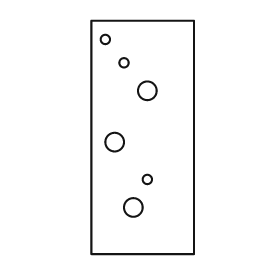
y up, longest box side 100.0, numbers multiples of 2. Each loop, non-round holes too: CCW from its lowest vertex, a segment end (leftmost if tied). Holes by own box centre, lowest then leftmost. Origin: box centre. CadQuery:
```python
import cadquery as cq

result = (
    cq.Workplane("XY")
    .moveTo(-22.0, -50.0)
    .lineTo(22.0, -50.0)
    .lineTo(22.0, 50.0)
    .lineTo(-22.0, 50.0)
    .close()
    .moveTo(-4.0, -30.0)
    .circle(4.0)
    .moveTo(2.0, -18.0)
    .circle(2.0)
    .moveTo(-12.0, -2.0)
    .circle(4.0)
    .moveTo(2.0, 20.0)
    .circle(4.0)
    .moveTo(-8.0, 32.0)
    .circle(2.0)
    .moveTo(-16.0, 42.0)
    .circle(2.0)
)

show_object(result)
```